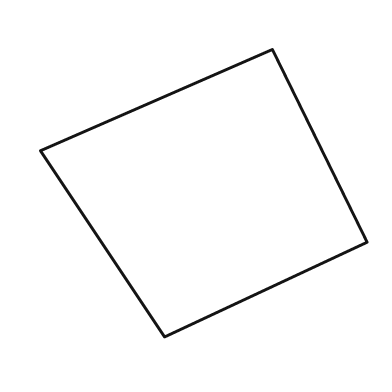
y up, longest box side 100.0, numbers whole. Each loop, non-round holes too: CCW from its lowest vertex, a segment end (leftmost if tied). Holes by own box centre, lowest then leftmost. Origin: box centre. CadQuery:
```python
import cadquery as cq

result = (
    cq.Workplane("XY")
    .moveTo(-12.0, -44.0)
    .lineTo(50.0, -15.0)
    .lineTo(21.0, 44.0)
    .lineTo(-50.0, 13.0)
    .close()
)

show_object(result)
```